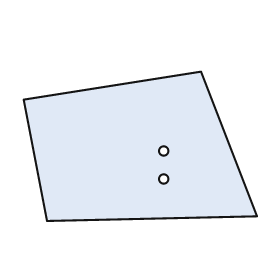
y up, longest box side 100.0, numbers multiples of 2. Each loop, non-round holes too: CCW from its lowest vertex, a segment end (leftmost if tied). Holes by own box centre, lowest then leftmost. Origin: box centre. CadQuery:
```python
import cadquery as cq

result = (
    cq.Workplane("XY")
    .moveTo(-40.0, -32.0)
    .lineTo(50.0, -30.0)
    .lineTo(26.0, 32.0)
    .lineTo(-50.0, 20.0)
    .close()
    .moveTo(10.0, -14.0)
    .circle(2.0)
    .moveTo(10.0, -2.0)
    .circle(2.0)
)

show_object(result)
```